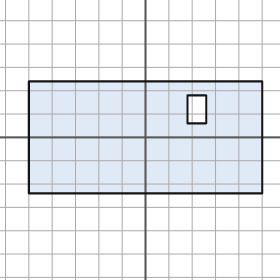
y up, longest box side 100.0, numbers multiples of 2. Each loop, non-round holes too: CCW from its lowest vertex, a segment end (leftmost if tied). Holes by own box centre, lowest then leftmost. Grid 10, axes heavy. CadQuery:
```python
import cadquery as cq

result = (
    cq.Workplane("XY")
    .moveTo(-50.0, -24.0)
    .lineTo(50.0, -24.0)
    .lineTo(50.0, 24.0)
    .lineTo(-50.0, 24.0)
    .close()
    .moveTo(18.0, 6.0)
    .lineTo(26.0, 6.0)
    .lineTo(26.0, 18.0)
    .lineTo(18.0, 18.0)
    .close()
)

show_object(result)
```